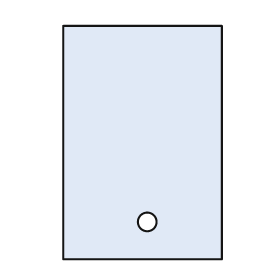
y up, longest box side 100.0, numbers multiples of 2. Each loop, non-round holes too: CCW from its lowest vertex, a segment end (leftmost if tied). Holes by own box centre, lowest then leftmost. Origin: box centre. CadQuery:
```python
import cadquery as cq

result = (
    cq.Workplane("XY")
    .moveTo(-34.0, -50.0)
    .lineTo(34.0, -50.0)
    .lineTo(34.0, 50.0)
    .lineTo(-34.0, 50.0)
    .close()
    .moveTo(2.0, -34.0)
    .circle(4.0)
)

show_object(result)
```